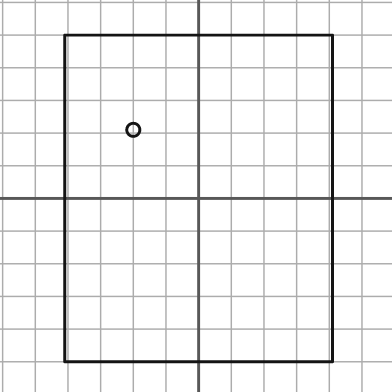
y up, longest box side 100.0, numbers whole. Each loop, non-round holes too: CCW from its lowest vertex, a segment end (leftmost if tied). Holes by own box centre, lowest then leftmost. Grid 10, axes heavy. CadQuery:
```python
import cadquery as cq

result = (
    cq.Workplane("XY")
    .moveTo(-41.0, -50.0)
    .lineTo(41.0, -50.0)
    .lineTo(41.0, 50.0)
    .lineTo(-41.0, 50.0)
    .close()
    .moveTo(-20.0, 21.0)
    .circle(2.0)
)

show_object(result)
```